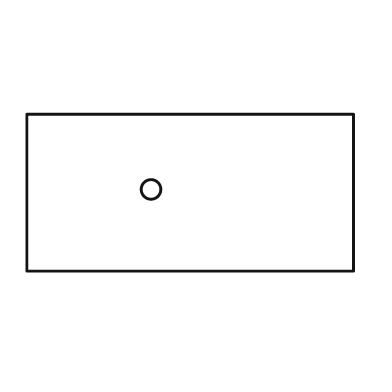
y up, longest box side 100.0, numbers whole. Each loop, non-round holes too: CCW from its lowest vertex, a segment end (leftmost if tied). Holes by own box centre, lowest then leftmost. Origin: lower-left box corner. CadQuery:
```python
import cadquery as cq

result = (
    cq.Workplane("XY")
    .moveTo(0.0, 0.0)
    .lineTo(100.0, 0.0)
    .lineTo(100.0, 48.0)
    .lineTo(0.0, 48.0)
    .close()
    .moveTo(38.0, 25.0)
    .circle(3.0)
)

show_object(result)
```